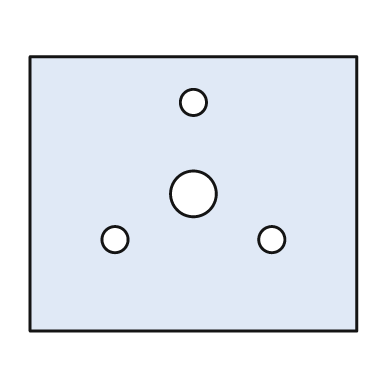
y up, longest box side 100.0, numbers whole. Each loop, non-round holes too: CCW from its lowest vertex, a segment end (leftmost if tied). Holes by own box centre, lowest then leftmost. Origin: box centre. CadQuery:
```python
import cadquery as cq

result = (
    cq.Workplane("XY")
    .moveTo(-50.0, -42.0)
    .lineTo(50.0, -42.0)
    .lineTo(50.0, 42.0)
    .lineTo(-50.0, 42.0)
    .close()
    .moveTo(-24.0, -14.0)
    .circle(4.0)
    .moveTo(24.0, -14.0)
    .circle(4.0)
    .moveTo(0.0, 0.0)
    .circle(7.0)
    .moveTo(0.0, 28.0)
    .circle(4.0)
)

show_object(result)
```